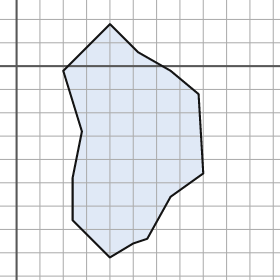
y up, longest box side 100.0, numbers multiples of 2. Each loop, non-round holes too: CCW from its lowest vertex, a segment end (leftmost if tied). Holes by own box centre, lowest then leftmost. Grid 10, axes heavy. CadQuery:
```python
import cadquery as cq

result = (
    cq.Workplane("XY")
    .moveTo(40.0, -82.0)
    .lineTo(50.0, -76.0)
    .lineTo(56.0, -74.0)
    .lineTo(66.0, -56.0)
    .lineTo(80.0, -46.0)
    .lineTo(78.0, -12.0)
    .lineTo(66.0, -2.0)
    .lineTo(52.0, 6.0)
    .lineTo(40.0, 18.0)
    .lineTo(20.0, -2.0)
    .lineTo(28.0, -28.0)
    .lineTo(24.0, -48.0)
    .lineTo(24.0, -66.0)
    .close()
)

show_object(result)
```